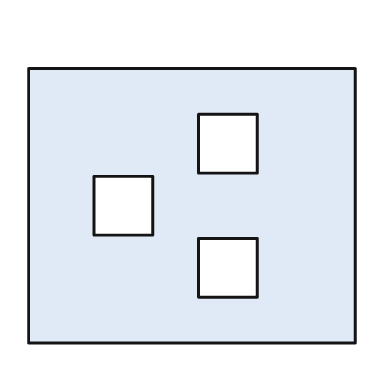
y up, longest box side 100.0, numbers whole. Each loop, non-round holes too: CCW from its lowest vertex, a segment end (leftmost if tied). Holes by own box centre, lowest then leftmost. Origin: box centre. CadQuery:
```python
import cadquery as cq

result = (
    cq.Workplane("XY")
    .moveTo(-50.0, -42.0)
    .lineTo(50.0, -42.0)
    .lineTo(50.0, 42.0)
    .lineTo(-50.0, 42.0)
    .close()
    .moveTo(2.0, -28.0)
    .lineTo(20.0, -28.0)
    .lineTo(20.0, -10.0)
    .lineTo(2.0, -10.0)
    .close()
    .moveTo(-30.0, -9.0)
    .lineTo(-12.0, -9.0)
    .lineTo(-12.0, 9.0)
    .lineTo(-30.0, 9.0)
    .close()
    .moveTo(2.0, 10.0)
    .lineTo(20.0, 10.0)
    .lineTo(20.0, 28.0)
    .lineTo(2.0, 28.0)
    .close()
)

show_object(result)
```